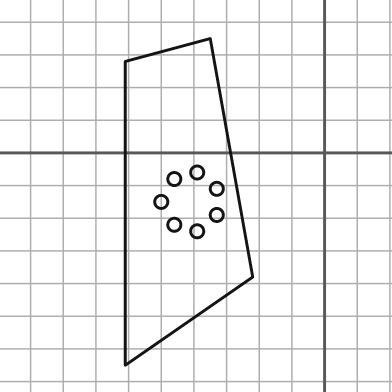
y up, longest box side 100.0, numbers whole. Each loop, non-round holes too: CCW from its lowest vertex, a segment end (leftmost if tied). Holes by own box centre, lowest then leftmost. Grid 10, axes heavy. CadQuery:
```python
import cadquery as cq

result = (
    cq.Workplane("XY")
    .moveTo(-61.0, -65.0)
    .lineTo(-22.0, -38.0)
    .lineTo(-35.0, 35.0)
    .lineTo(-61.0, 28.0)
    .close()
    .moveTo(-39.0, -24.0)
    .circle(2.0)
    .moveTo(-46.0, -22.0)
    .circle(2.0)
    .moveTo(-33.0, -19.0)
    .circle(2.0)
    .moveTo(-50.0, -15.0)
    .circle(2.0)
    .moveTo(-33.0, -11.0)
    .circle(2.0)
    .moveTo(-46.0, -8.0)
    .circle(2.0)
    .moveTo(-39.0, -6.0)
    .circle(2.0)
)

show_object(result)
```